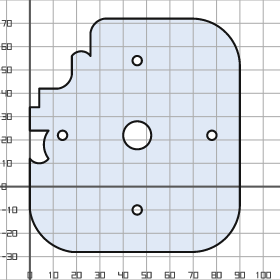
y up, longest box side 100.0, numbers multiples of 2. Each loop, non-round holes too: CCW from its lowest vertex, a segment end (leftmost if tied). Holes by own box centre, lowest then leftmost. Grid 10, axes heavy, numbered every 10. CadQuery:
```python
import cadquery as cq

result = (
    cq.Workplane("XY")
    .moveTo(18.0, -28.0)
    .lineTo(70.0, -28.0)
    .threePointArc((84.0, -22.0), (90.0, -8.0))
    .lineTo(90.0, 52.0)
    .threePointArc((84.0, 66.0), (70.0, 72.0))
    .lineTo(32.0, 72.0)
    .threePointArc((28.0, 70.0), (26.0, 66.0))
    .lineTo(26.0, 56.0)
    .threePointArc((22.0, 58.0), (18.0, 56.0))
    .lineTo(18.0, 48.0)
    .threePointArc((16.0, 44.0), (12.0, 42.0))
    .lineTo(4.0, 42.0)
    .lineTo(4.0, 34.0)
    .lineTo(0.0, 34.0)
    .lineTo(0.0, 24.0)
    .lineTo(8.0, 24.0)
    .threePointArc((6.0, 18.0), (8.0, 12.0))
    .threePointArc((4.0, 10.0), (0.0, 12.0))
    .lineTo(0.0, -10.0)
    .threePointArc((6.0, -22.0), (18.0, -28.0))
    .close()
    .moveTo(46.0, -10.0)
    .circle(2.0)
    .moveTo(14.0, 22.0)
    .circle(2.0)
    .moveTo(46.0, 22.0)
    .circle(6.0)
    .moveTo(78.0, 22.0)
    .circle(2.0)
    .moveTo(46.0, 54.0)
    .circle(2.0)
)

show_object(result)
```